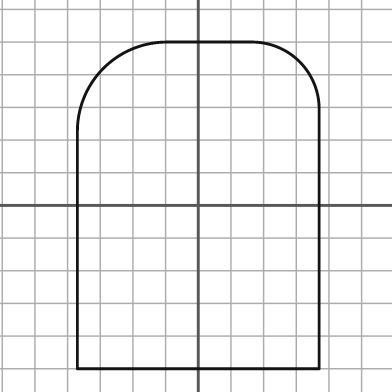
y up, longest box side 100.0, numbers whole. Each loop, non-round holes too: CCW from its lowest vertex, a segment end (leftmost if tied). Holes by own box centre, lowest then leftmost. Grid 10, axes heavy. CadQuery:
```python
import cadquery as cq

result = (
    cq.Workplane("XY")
    .moveTo(-37.0, -50.0)
    .lineTo(37.0, -50.0)
    .lineTo(37.0, 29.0)
    .threePointArc((31.0, 44.0), (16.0, 50.0))
    .lineTo(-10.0, 50.0)
    .threePointArc((-29.0, 42.0), (-37.0, 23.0))
    .close()
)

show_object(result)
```